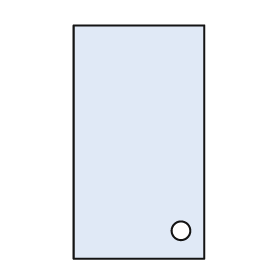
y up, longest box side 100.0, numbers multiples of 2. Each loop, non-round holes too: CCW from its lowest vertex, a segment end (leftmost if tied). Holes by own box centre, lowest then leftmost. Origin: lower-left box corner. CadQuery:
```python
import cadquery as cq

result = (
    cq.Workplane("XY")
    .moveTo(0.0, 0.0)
    .lineTo(56.0, 0.0)
    .lineTo(56.0, 100.0)
    .lineTo(0.0, 100.0)
    .close()
    .moveTo(46.0, 12.0)
    .circle(4.0)
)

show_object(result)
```